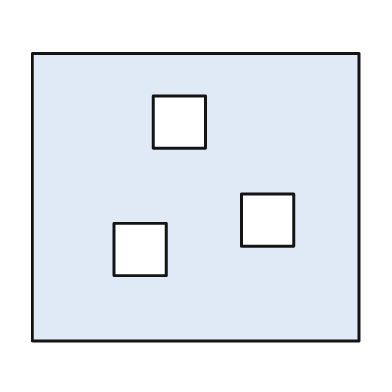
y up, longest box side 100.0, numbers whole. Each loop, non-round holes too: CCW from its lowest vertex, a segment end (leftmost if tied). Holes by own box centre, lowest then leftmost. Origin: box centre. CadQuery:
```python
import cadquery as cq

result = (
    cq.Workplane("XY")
    .moveTo(-50.0, -44.0)
    .lineTo(50.0, -44.0)
    .lineTo(50.0, 44.0)
    .lineTo(-50.0, 44.0)
    .close()
    .moveTo(-25.0, -24.0)
    .lineTo(-9.0, -24.0)
    .lineTo(-9.0, -8.0)
    .lineTo(-25.0, -8.0)
    .close()
    .moveTo(14.0, -15.0)
    .lineTo(30.0, -15.0)
    .lineTo(30.0, 1.0)
    .lineTo(14.0, 1.0)
    .close()
    .moveTo(-13.0, 15.0)
    .lineTo(3.0, 15.0)
    .lineTo(3.0, 31.0)
    .lineTo(-13.0, 31.0)
    .close()
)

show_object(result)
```